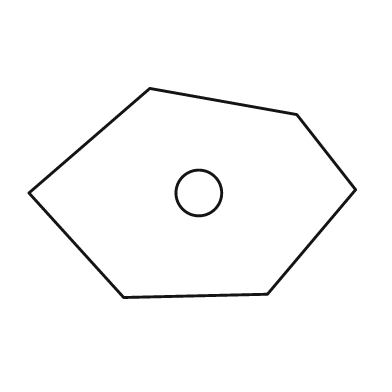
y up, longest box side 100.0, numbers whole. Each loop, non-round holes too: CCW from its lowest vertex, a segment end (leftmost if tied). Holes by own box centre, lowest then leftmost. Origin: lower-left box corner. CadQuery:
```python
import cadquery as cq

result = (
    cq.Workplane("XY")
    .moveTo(29.0, 0.0)
    .lineTo(73.0, 1.0)
    .lineTo(100.0, 33.0)
    .lineTo(82.0, 56.0)
    .lineTo(37.0, 64.0)
    .lineTo(0.0, 32.0)
    .close()
    .moveTo(52.0, 32.0)
    .circle(7.0)
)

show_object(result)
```